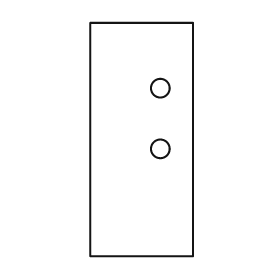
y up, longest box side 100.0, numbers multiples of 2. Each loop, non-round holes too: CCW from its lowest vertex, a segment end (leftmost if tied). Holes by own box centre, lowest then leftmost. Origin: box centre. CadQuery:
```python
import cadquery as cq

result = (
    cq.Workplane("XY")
    .moveTo(-22.0, -50.0)
    .lineTo(22.0, -50.0)
    .lineTo(22.0, 50.0)
    .lineTo(-22.0, 50.0)
    .close()
    .moveTo(8.0, -4.0)
    .circle(4.0)
    .moveTo(8.0, 22.0)
    .circle(4.0)
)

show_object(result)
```